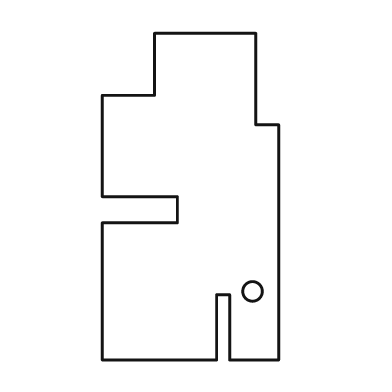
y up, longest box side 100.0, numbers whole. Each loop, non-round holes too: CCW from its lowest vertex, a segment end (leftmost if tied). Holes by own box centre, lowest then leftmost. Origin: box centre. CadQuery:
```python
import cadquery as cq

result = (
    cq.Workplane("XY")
    .moveTo(-27.0, -50.0)
    .lineTo(8.0, -50.0)
    .lineTo(8.0, -30.0)
    .lineTo(12.0, -30.0)
    .lineTo(12.0, -50.0)
    .lineTo(27.0, -50.0)
    .lineTo(27.0, 22.0)
    .lineTo(20.0, 22.0)
    .lineTo(20.0, 50.0)
    .lineTo(-11.0, 50.0)
    .lineTo(-11.0, 31.0)
    .lineTo(-27.0, 31.0)
    .lineTo(-27.0, 0.0)
    .lineTo(-4.0, 0.0)
    .lineTo(-4.0, -8.0)
    .lineTo(-27.0, -8.0)
    .close()
    .moveTo(19.0, -29.0)
    .circle(3.0)
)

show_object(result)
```